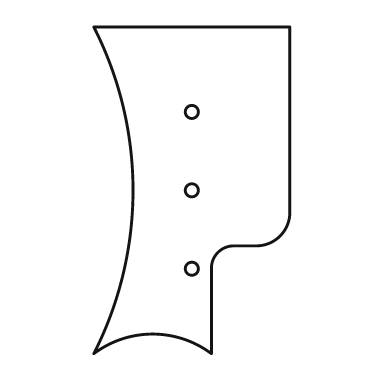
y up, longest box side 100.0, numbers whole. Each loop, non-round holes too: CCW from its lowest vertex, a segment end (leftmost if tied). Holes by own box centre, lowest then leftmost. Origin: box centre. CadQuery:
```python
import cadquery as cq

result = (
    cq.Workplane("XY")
    .moveTo(-30.0, -50.0)
    .threePointArc((-12.0, -44.0), (6.0, -50.0))
    .lineTo(6.0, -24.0)
    .threePointArc((8.0, -19.0), (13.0, -17.0))
    .lineTo(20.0, -17.0)
    .threePointArc((27.0, -14.0), (30.0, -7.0))
    .lineTo(30.0, 50.0)
    .lineTo(-30.0, 50.0)
    .threePointArc((-18.0, 0.0), (-30.0, -50.0))
    .close()
    .moveTo(0.0, -24.0)
    .circle(2.0)
    .moveTo(0.0, 0.0)
    .circle(2.0)
    .moveTo(0.0, 24.0)
    .circle(2.0)
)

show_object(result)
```